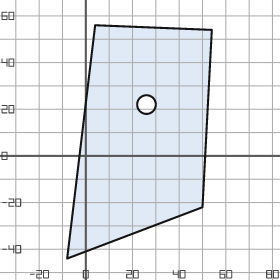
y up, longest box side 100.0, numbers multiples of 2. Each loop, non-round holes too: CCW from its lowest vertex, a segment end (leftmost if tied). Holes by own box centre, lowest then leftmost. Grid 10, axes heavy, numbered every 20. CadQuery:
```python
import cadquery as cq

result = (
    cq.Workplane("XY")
    .moveTo(-8.0, -44.0)
    .lineTo(50.0, -22.0)
    .lineTo(54.0, 54.0)
    .lineTo(4.0, 56.0)
    .close()
    .moveTo(26.0, 22.0)
    .circle(4.0)
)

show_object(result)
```